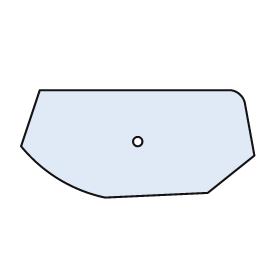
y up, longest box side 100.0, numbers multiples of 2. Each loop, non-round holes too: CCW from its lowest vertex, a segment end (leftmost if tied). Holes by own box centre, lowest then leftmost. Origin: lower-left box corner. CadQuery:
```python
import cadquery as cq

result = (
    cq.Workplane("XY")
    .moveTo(36.0, 0.0)
    .lineTo(80.0, 2.0)
    .lineTo(100.0, 18.0)
    .lineTo(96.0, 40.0)
    .threePointArc((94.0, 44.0), (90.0, 46.0))
    .lineTo(8.0, 46.0)
    .lineTo(0.0, 22.0)
    .threePointArc((16.0, 8.0), (36.0, 0.0))
    .close()
    .moveTo(50.0, 24.0)
    .circle(2.0)
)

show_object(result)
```